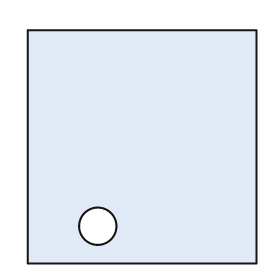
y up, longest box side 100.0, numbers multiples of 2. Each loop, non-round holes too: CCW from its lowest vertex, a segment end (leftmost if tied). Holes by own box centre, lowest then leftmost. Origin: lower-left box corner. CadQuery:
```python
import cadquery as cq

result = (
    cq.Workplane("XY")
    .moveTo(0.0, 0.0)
    .lineTo(98.0, 0.0)
    .lineTo(98.0, 100.0)
    .lineTo(0.0, 100.0)
    .close()
    .moveTo(30.0, 16.0)
    .circle(8.0)
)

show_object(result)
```